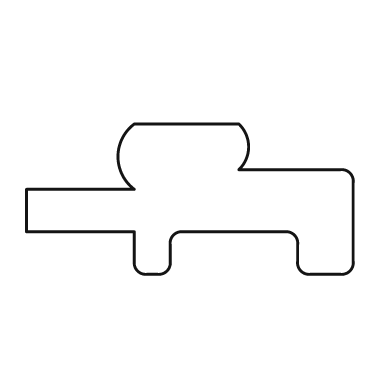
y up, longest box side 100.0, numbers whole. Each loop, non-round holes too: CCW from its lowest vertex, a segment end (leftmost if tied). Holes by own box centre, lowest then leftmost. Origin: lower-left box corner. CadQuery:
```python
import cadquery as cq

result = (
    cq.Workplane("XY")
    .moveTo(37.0, 0.0)
    .lineTo(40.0, 0.0)
    .threePointArc((43.0, 1.0), (44.0, 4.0))
    .lineTo(44.0, 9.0)
    .threePointArc((45.0, 12.0), (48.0, 13.0))
    .lineTo(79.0, 13.0)
    .threePointArc((82.0, 12.0), (83.0, 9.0))
    .lineTo(83.0, 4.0)
    .threePointArc((84.0, 1.0), (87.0, 0.0))
    .lineTo(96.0, 0.0)
    .threePointArc((99.0, 1.0), (100.0, 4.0))
    .lineTo(100.0, 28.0)
    .threePointArc((99.0, 31.0), (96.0, 32.0))
    .lineTo(65.0, 32.0)
    .threePointArc((68.0, 39.0), (65.0, 46.0))
    .lineTo(33.0, 46.0)
    .threePointArc((28.0, 36.0), (33.0, 26.0))
    .lineTo(0.0, 26.0)
    .lineTo(0.0, 13.0)
    .lineTo(33.0, 13.0)
    .lineTo(33.0, 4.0)
    .threePointArc((34.0, 1.0), (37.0, 0.0))
    .close()
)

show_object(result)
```